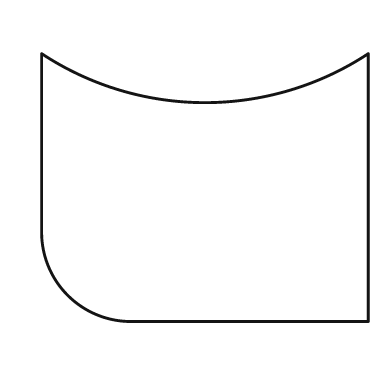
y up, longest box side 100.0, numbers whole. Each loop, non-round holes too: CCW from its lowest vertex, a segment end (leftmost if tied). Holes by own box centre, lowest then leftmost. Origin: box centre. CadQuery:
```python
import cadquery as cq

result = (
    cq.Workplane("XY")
    .moveTo(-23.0, -41.0)
    .lineTo(50.0, -41.0)
    .lineTo(50.0, 41.0)
    .threePointArc((0.0, 26.0), (-50.0, 41.0))
    .lineTo(-50.0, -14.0)
    .threePointArc((-42.0, -33.0), (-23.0, -41.0))
    .close()
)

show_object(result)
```